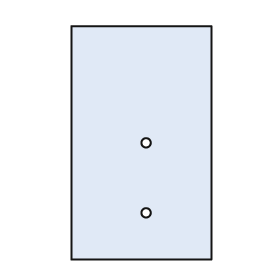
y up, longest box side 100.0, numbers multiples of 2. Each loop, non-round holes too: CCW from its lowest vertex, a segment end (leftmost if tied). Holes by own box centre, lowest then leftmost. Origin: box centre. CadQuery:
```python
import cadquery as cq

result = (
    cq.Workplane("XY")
    .moveTo(-30.0, -50.0)
    .lineTo(30.0, -50.0)
    .lineTo(30.0, 50.0)
    .lineTo(-30.0, 50.0)
    .close()
    .moveTo(2.0, -30.0)
    .circle(2.0)
    .moveTo(2.0, 0.0)
    .circle(2.0)
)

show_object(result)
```